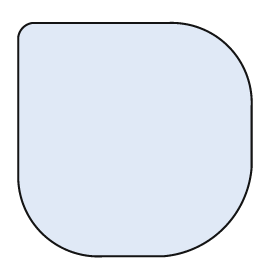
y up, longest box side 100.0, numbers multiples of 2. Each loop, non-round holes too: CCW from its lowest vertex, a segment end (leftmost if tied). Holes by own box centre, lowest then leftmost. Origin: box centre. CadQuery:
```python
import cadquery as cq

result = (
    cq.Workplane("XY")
    .moveTo(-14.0, -50.0)
    .lineTo(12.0, -50.0)
    .threePointArc((38.0, -38.0), (50.0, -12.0))
    .lineTo(50.0, 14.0)
    .threePointArc((40.0, 40.0), (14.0, 50.0))
    .lineTo(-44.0, 50.0)
    .threePointArc((-48.0, 48.0), (-50.0, 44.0))
    .lineTo(-50.0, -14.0)
    .threePointArc((-40.0, -40.0), (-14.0, -50.0))
    .close()
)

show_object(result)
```